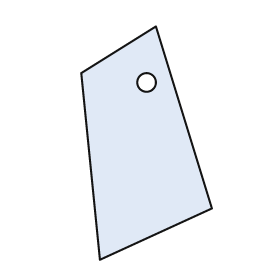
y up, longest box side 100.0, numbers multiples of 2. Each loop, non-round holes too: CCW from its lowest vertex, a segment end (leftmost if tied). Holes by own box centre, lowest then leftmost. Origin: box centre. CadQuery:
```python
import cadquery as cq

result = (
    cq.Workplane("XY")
    .moveTo(-20.0, -50.0)
    .lineTo(28.0, -28.0)
    .lineTo(4.0, 50.0)
    .lineTo(-28.0, 30.0)
    .close()
    .moveTo(0.0, 26.0)
    .circle(4.0)
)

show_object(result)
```